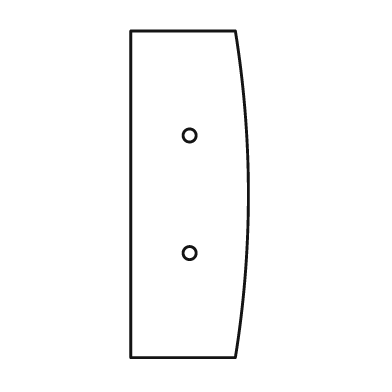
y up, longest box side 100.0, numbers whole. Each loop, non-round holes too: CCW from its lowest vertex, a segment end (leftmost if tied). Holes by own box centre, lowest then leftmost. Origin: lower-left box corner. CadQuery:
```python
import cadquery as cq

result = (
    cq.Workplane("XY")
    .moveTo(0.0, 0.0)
    .lineTo(32.0, 0.0)
    .threePointArc((36.0, 50.0), (32.0, 100.0))
    .lineTo(0.0, 100.0)
    .close()
    .moveTo(18.0, 32.0)
    .circle(2.0)
    .moveTo(18.0, 68.0)
    .circle(2.0)
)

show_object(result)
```